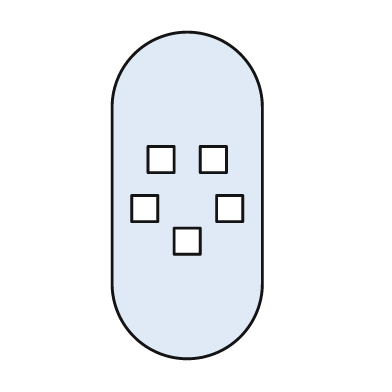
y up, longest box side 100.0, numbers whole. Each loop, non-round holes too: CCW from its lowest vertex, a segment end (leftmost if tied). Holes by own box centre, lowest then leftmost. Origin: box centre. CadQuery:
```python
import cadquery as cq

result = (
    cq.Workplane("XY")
    .moveTo(-23.0, -27.0)
    .threePointArc((0.0, -50.0), (23.0, -27.0))
    .lineTo(23.0, 27.0)
    .threePointArc((0.0, 50.0), (-23.0, 27.0))
    .close()
    .moveTo(-4.0, -18.0)
    .lineTo(4.0, -18.0)
    .lineTo(4.0, -10.0)
    .lineTo(-4.0, -10.0)
    .close()
    .moveTo(-17.0, -8.0)
    .lineTo(-9.0, -8.0)
    .lineTo(-9.0, 0.0)
    .lineTo(-17.0, 0.0)
    .close()
    .moveTo(9.0, -8.0)
    .lineTo(17.0, -8.0)
    .lineTo(17.0, 0.0)
    .lineTo(9.0, 0.0)
    .close()
    .moveTo(-12.0, 7.0)
    .lineTo(-4.0, 7.0)
    .lineTo(-4.0, 15.0)
    .lineTo(-12.0, 15.0)
    .close()
    .moveTo(4.0, 7.0)
    .lineTo(12.0, 7.0)
    .lineTo(12.0, 15.0)
    .lineTo(4.0, 15.0)
    .close()
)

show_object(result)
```